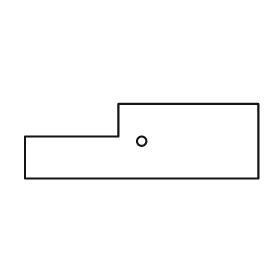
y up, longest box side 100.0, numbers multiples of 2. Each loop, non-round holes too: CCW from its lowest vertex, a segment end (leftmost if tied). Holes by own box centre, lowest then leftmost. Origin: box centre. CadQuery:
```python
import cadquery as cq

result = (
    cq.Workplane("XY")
    .moveTo(-50.0, -16.0)
    .lineTo(50.0, -16.0)
    .lineTo(50.0, 16.0)
    .lineTo(-10.0, 16.0)
    .lineTo(-10.0, 2.0)
    .lineTo(-50.0, 2.0)
    .close()
    .moveTo(0.0, 0.0)
    .circle(2.0)
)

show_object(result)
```